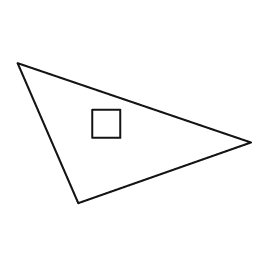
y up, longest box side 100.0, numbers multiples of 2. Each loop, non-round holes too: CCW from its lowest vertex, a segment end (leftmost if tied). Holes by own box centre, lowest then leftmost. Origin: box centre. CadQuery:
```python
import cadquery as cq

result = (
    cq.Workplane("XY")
    .moveTo(-24.0, -30.0)
    .lineTo(50.0, -4.0)
    .lineTo(-50.0, 30.0)
    .close()
    .moveTo(-18.0, -2.0)
    .lineTo(-6.0, -2.0)
    .lineTo(-6.0, 10.0)
    .lineTo(-18.0, 10.0)
    .close()
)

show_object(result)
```